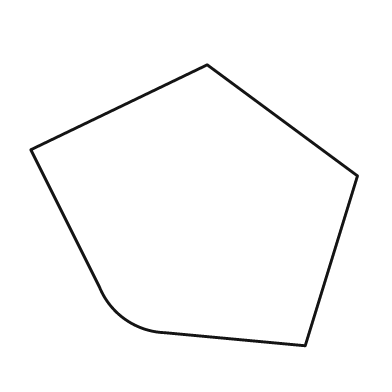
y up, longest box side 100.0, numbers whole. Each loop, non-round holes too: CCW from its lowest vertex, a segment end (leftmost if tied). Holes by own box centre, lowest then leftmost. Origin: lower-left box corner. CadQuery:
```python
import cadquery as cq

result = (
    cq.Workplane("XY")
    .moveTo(84.0, 0.0)
    .lineTo(100.0, 52.0)
    .lineTo(54.0, 86.0)
    .lineTo(0.0, 60.0)
    .lineTo(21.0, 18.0)
    .threePointArc((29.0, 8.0), (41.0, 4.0))
    .close()
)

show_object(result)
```